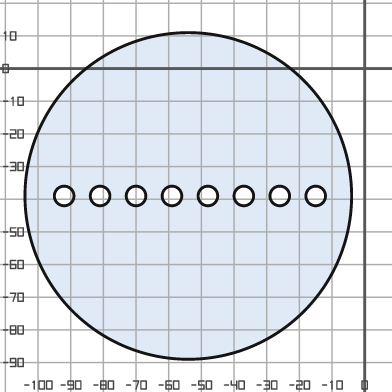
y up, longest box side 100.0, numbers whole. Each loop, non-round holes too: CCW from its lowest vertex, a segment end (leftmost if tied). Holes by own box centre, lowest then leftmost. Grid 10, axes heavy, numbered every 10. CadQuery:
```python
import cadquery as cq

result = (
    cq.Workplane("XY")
    .moveTo(-54.0, -39.0)
    .circle(50.0)
    .moveTo(-92.0, -39.0)
    .circle(3.0)
    .moveTo(-81.0, -39.0)
    .circle(3.0)
    .moveTo(-70.0, -39.0)
    .circle(3.0)
    .moveTo(-59.0, -39.0)
    .circle(3.0)
    .moveTo(-48.0, -39.0)
    .circle(3.0)
    .moveTo(-37.0, -39.0)
    .circle(3.0)
    .moveTo(-26.0, -39.0)
    .circle(3.0)
    .moveTo(-15.0, -39.0)
    .circle(3.0)
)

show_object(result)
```